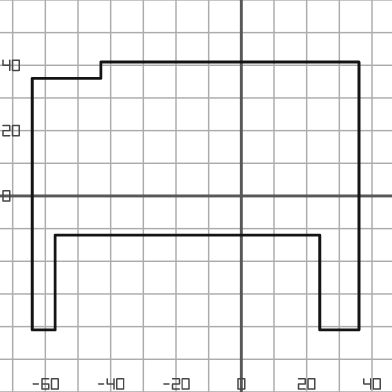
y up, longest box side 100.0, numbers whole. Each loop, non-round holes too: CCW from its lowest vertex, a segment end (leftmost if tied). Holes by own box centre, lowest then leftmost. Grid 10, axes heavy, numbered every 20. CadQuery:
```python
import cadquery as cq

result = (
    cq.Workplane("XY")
    .moveTo(-64.0, -41.0)
    .lineTo(-57.0, -41.0)
    .lineTo(-57.0, -12.0)
    .lineTo(24.0, -12.0)
    .lineTo(24.0, -41.0)
    .lineTo(36.0, -41.0)
    .lineTo(36.0, 41.0)
    .lineTo(-43.0, 41.0)
    .lineTo(-43.0, 36.0)
    .lineTo(-64.0, 36.0)
    .close()
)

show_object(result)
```